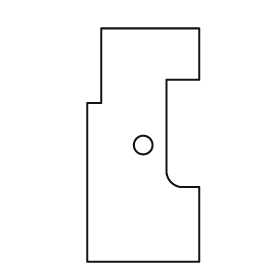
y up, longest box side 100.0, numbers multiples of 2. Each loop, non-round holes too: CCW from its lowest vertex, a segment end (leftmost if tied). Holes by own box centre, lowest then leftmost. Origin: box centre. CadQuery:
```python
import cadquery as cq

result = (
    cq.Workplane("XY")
    .moveTo(-24.0, -50.0)
    .lineTo(24.0, -50.0)
    .lineTo(24.0, -18.0)
    .lineTo(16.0, -18.0)
    .threePointArc((12.0, -16.0), (10.0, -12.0))
    .lineTo(10.0, 28.0)
    .lineTo(24.0, 28.0)
    .lineTo(24.0, 50.0)
    .lineTo(-18.0, 50.0)
    .lineTo(-18.0, 18.0)
    .lineTo(-24.0, 18.0)
    .close()
    .moveTo(0.0, 0.0)
    .circle(4.0)
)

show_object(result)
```